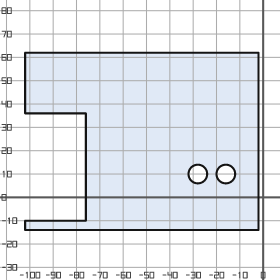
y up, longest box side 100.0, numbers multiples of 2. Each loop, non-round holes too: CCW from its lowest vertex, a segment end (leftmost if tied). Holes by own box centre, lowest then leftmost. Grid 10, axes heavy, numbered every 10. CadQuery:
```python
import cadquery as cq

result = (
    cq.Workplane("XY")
    .moveTo(-102.0, -14.0)
    .lineTo(-2.0, -14.0)
    .lineTo(-2.0, 62.0)
    .lineTo(-102.0, 62.0)
    .lineTo(-102.0, 36.0)
    .lineTo(-76.0, 36.0)
    .lineTo(-76.0, -10.0)
    .lineTo(-102.0, -10.0)
    .close()
    .moveTo(-28.0, 10.0)
    .circle(4.0)
    .moveTo(-16.0, 10.0)
    .circle(4.0)
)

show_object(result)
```